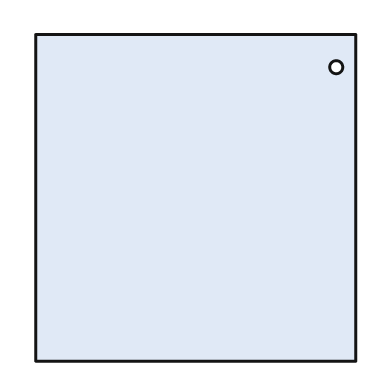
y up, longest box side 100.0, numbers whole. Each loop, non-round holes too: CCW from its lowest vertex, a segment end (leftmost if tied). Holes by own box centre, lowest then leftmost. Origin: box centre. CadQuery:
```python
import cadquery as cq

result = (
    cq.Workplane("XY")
    .moveTo(-49.0, -50.0)
    .lineTo(49.0, -50.0)
    .lineTo(49.0, 50.0)
    .lineTo(-49.0, 50.0)
    .close()
    .moveTo(43.0, 40.0)
    .circle(2.0)
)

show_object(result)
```